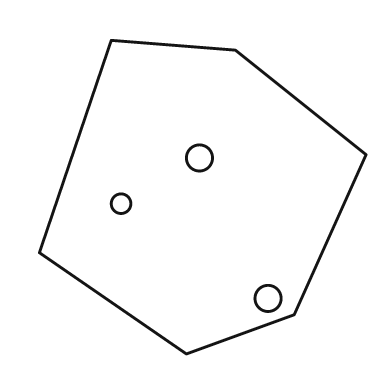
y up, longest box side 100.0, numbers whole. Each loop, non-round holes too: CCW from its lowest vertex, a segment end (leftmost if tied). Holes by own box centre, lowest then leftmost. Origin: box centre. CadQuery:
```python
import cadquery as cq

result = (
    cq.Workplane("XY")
    .moveTo(-5.0, -48.0)
    .lineTo(28.0, -36.0)
    .lineTo(50.0, 13.0)
    .lineTo(10.0, 45.0)
    .lineTo(-28.0, 48.0)
    .lineTo(-50.0, -17.0)
    .close()
    .moveTo(20.0, -31.0)
    .circle(4.0)
    .moveTo(-25.0, -2.0)
    .circle(3.0)
    .moveTo(-1.0, 12.0)
    .circle(4.0)
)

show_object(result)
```